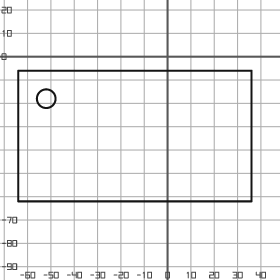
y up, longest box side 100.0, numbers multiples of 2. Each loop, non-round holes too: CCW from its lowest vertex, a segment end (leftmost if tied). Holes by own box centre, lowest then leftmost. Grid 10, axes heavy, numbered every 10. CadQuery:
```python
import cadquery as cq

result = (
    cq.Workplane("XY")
    .moveTo(-64.0, -62.0)
    .lineTo(36.0, -62.0)
    .lineTo(36.0, -6.0)
    .lineTo(-64.0, -6.0)
    .close()
    .moveTo(-52.0, -18.0)
    .circle(4.0)
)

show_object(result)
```